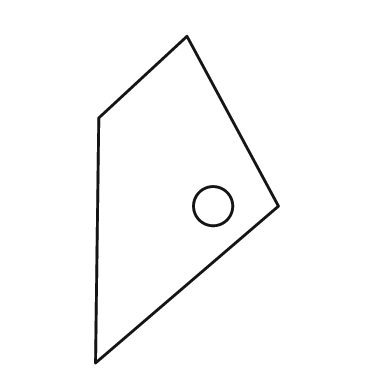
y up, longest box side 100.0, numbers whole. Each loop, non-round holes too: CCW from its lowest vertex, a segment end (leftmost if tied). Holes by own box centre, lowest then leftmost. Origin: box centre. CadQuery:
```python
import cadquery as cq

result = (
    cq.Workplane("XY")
    .moveTo(-28.0, -50.0)
    .lineTo(28.0, -2.0)
    .lineTo(0.0, 50.0)
    .lineTo(-27.0, 25.0)
    .close()
    .moveTo(8.0, -2.0)
    .circle(6.0)
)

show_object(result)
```